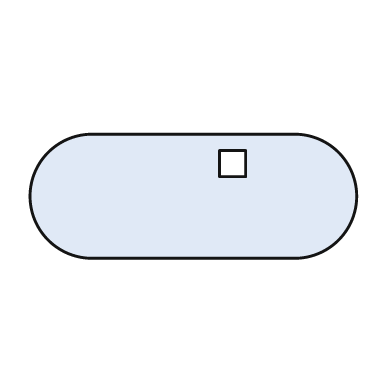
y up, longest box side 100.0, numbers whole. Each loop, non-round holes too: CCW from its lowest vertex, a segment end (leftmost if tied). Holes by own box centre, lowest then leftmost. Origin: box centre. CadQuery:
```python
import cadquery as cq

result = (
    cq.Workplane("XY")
    .moveTo(-31.0, -19.0)
    .lineTo(31.0, -19.0)
    .threePointArc((50.0, 0.0), (31.0, 19.0))
    .lineTo(-31.0, 19.0)
    .threePointArc((-50.0, 0.0), (-31.0, -19.0))
    .close()
    .moveTo(8.0, 6.0)
    .lineTo(16.0, 6.0)
    .lineTo(16.0, 14.0)
    .lineTo(8.0, 14.0)
    .close()
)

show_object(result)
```